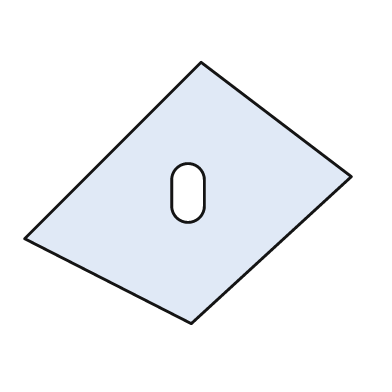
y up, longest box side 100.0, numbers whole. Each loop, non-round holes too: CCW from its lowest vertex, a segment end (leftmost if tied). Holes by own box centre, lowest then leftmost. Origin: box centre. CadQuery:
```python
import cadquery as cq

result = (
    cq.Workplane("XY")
    .moveTo(1.0, -40.0)
    .lineTo(50.0, 5.0)
    .lineTo(4.0, 40.0)
    .lineTo(-50.0, -14.0)
    .close()
    .moveTo(-5.0, -4.0)
    .threePointArc((0.0, -9.0), (5.0, -4.0))
    .lineTo(5.0, 4.0)
    .threePointArc((0.0, 9.0), (-5.0, 4.0))
    .close()
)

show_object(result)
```